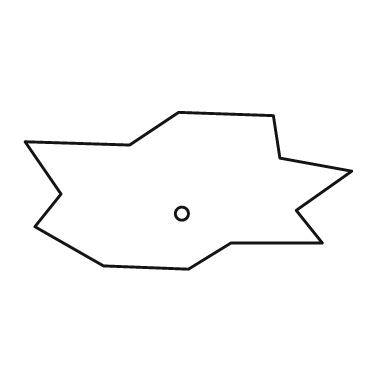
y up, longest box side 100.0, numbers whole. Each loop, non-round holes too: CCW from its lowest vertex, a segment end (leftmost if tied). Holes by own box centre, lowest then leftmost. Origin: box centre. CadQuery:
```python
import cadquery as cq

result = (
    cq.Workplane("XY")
    .moveTo(0.0, -24.0)
    .lineTo(13.0, -16.0)
    .lineTo(41.0, -16.0)
    .lineTo(33.0, -6.0)
    .lineTo(50.0, 6.0)
    .lineTo(28.0, 10.0)
    .lineTo(26.0, 23.0)
    .lineTo(-3.0, 24.0)
    .lineTo(-18.0, 14.0)
    .lineTo(-50.0, 15.0)
    .lineTo(-39.0, -1.0)
    .lineTo(-47.0, -11.0)
    .lineTo(-26.0, -23.0)
    .close()
    .moveTo(-2.0, -7.0)
    .circle(2.0)
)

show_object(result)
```